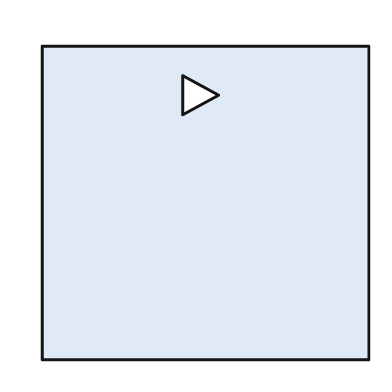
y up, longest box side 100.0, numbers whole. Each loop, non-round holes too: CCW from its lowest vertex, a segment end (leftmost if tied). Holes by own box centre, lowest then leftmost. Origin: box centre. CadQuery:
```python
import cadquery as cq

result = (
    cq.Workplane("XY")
    .moveTo(-50.0, -48.0)
    .lineTo(50.0, -48.0)
    .lineTo(50.0, 48.0)
    .lineTo(-50.0, 48.0)
    .close()
    .moveTo(-7.0, 27.0)
    .lineTo(4.0, 33.0)
    .lineTo(-7.0, 39.0)
    .close()
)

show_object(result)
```